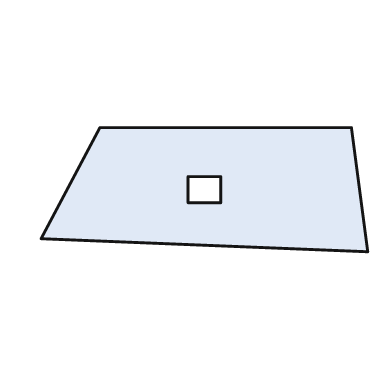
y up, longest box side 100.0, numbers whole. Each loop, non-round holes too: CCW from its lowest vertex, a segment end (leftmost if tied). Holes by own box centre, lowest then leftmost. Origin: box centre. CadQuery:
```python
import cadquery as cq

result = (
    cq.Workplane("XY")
    .moveTo(50.0, -19.0)
    .lineTo(45.0, 19.0)
    .lineTo(-32.0, 19.0)
    .lineTo(-50.0, -15.0)
    .close()
    .moveTo(-5.0, -4.0)
    .lineTo(5.0, -4.0)
    .lineTo(5.0, 4.0)
    .lineTo(-5.0, 4.0)
    .close()
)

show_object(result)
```